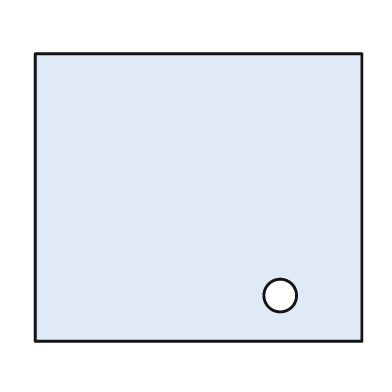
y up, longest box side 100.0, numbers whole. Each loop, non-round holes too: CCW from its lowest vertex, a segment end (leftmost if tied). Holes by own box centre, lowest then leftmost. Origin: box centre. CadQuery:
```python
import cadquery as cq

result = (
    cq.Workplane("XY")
    .moveTo(-50.0, -44.0)
    .lineTo(50.0, -44.0)
    .lineTo(50.0, 44.0)
    .lineTo(-50.0, 44.0)
    .close()
    .moveTo(25.0, -30.0)
    .circle(5.0)
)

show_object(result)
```